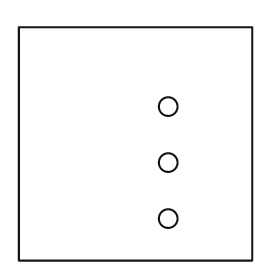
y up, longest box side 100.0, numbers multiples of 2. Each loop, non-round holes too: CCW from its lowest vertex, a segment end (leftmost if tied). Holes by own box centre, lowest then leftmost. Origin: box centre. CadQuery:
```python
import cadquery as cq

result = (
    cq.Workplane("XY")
    .moveTo(-50.0, -50.0)
    .lineTo(50.0, -50.0)
    .lineTo(50.0, 50.0)
    .lineTo(-50.0, 50.0)
    .close()
    .moveTo(14.0, -32.0)
    .circle(4.0)
    .moveTo(14.0, -8.0)
    .circle(4.0)
    .moveTo(14.0, 16.0)
    .circle(4.0)
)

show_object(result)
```